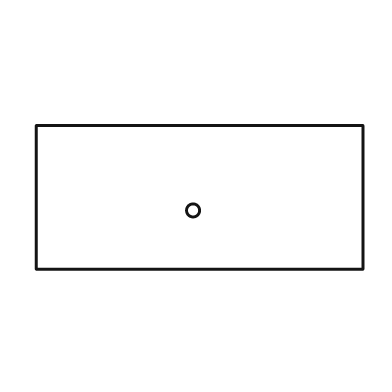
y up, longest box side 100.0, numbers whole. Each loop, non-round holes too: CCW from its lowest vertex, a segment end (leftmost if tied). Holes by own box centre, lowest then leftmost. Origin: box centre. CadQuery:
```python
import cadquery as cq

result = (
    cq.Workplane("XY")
    .moveTo(-50.0, -22.0)
    .lineTo(50.0, -22.0)
    .lineTo(50.0, 22.0)
    .lineTo(-50.0, 22.0)
    .close()
    .moveTo(-2.0, -4.0)
    .circle(2.0)
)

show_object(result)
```